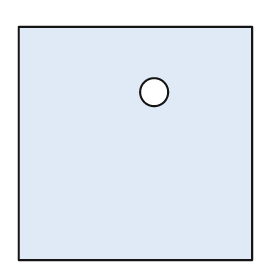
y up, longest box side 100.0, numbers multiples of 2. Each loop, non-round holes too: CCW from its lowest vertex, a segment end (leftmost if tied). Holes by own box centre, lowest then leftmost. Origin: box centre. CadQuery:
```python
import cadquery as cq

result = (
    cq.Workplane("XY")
    .moveTo(-50.0, -50.0)
    .lineTo(50.0, -50.0)
    .lineTo(50.0, 50.0)
    .lineTo(-50.0, 50.0)
    .close()
    .moveTo(8.0, 22.0)
    .circle(6.0)
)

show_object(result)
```